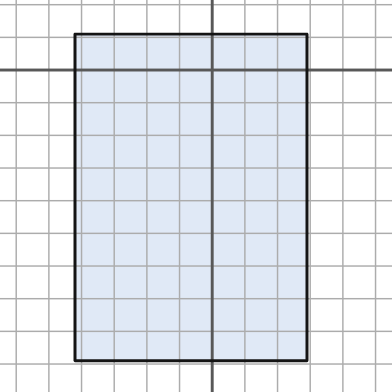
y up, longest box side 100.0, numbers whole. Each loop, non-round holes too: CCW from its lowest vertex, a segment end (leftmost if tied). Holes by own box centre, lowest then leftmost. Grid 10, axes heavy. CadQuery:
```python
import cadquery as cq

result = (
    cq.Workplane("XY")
    .moveTo(-42.0, -89.0)
    .lineTo(29.0, -89.0)
    .lineTo(29.0, 11.0)
    .lineTo(-42.0, 11.0)
    .close()
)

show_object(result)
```